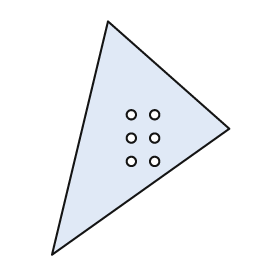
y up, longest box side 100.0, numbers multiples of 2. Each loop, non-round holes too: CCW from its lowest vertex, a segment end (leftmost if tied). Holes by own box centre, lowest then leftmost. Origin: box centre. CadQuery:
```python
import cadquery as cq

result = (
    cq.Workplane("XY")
    .moveTo(-38.0, -50.0)
    .lineTo(38.0, 4.0)
    .lineTo(-14.0, 50.0)
    .close()
    .moveTo(-4.0, -10.0)
    .circle(2.0)
    .moveTo(6.0, -10.0)
    .circle(2.0)
    .moveTo(-4.0, 0.0)
    .circle(2.0)
    .moveTo(6.0, 0.0)
    .circle(2.0)
    .moveTo(-4.0, 10.0)
    .circle(2.0)
    .moveTo(6.0, 10.0)
    .circle(2.0)
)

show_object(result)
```